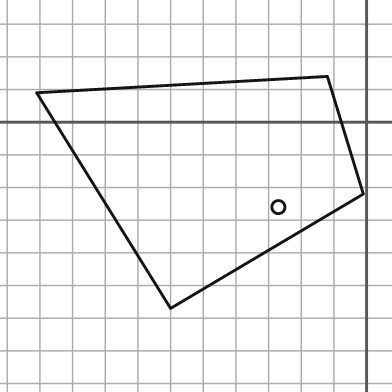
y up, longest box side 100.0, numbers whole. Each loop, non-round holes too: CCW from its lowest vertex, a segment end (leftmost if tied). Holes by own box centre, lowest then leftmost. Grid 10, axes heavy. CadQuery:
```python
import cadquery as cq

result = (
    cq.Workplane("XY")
    .moveTo(-60.0, -57.0)
    .lineTo(-1.0, -22.0)
    .lineTo(-12.0, 14.0)
    .lineTo(-101.0, 9.0)
    .close()
    .moveTo(-27.0, -26.0)
    .circle(2.0)
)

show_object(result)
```